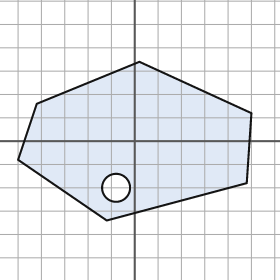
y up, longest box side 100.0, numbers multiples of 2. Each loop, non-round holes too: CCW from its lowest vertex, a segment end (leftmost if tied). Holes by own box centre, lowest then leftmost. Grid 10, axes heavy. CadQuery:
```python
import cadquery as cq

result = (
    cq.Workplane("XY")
    .moveTo(-12.0, -34.0)
    .lineTo(48.0, -18.0)
    .lineTo(50.0, 12.0)
    .lineTo(2.0, 34.0)
    .lineTo(-42.0, 16.0)
    .lineTo(-50.0, -8.0)
    .close()
    .moveTo(-8.0, -20.0)
    .circle(6.0)
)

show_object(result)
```